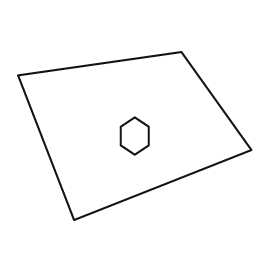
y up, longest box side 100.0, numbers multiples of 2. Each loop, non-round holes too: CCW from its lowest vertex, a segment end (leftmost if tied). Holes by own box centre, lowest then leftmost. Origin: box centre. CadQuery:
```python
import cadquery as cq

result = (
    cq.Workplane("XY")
    .moveTo(-26.0, -36.0)
    .lineTo(50.0, -6.0)
    .lineTo(20.0, 36.0)
    .lineTo(-50.0, 26.0)
    .close()
    .moveTo(0.0, -8.0)
    .lineTo(6.0, -4.0)
    .lineTo(6.0, 4.0)
    .lineTo(0.0, 8.0)
    .lineTo(-6.0, 4.0)
    .lineTo(-6.0, -4.0)
    .close()
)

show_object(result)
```